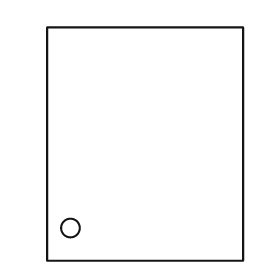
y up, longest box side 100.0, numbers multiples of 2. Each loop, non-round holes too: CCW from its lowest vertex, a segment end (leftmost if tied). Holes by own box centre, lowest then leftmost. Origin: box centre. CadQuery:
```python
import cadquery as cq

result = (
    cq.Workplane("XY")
    .moveTo(-42.0, -50.0)
    .lineTo(42.0, -50.0)
    .lineTo(42.0, 50.0)
    .lineTo(-42.0, 50.0)
    .close()
    .moveTo(-32.0, -36.0)
    .circle(4.0)
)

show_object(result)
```